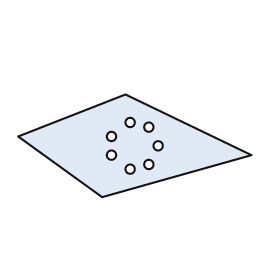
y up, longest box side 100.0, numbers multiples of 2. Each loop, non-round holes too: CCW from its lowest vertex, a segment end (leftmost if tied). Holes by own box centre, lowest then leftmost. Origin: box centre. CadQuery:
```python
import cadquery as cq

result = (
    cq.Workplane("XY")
    .moveTo(-14.0, -22.0)
    .lineTo(50.0, -4.0)
    .lineTo(-4.0, 22.0)
    .lineTo(-50.0, 4.0)
    .close()
    .moveTo(-2.0, -10.0)
    .circle(2.0)
    .moveTo(6.0, -8.0)
    .circle(2.0)
    .moveTo(-10.0, -4.0)
    .circle(2.0)
    .moveTo(10.0, 0.0)
    .circle(2.0)
    .moveTo(-10.0, 4.0)
    .circle(2.0)
    .moveTo(6.0, 8.0)
    .circle(2.0)
    .moveTo(-2.0, 10.0)
    .circle(2.0)
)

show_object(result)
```